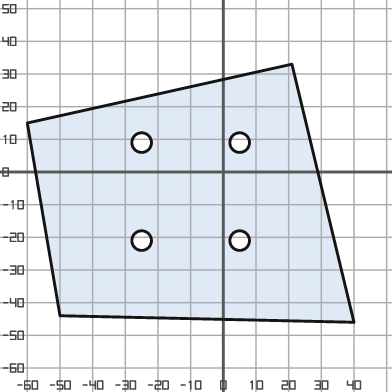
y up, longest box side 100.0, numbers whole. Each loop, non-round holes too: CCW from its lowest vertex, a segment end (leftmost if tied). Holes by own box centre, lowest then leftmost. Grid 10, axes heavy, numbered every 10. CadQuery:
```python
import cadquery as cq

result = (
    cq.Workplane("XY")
    .moveTo(40.0, -46.0)
    .lineTo(21.0, 33.0)
    .lineTo(-60.0, 15.0)
    .lineTo(-50.0, -44.0)
    .close()
    .moveTo(-25.0, -21.0)
    .circle(3.0)
    .moveTo(5.0, -21.0)
    .circle(3.0)
    .moveTo(-25.0, 9.0)
    .circle(3.0)
    .moveTo(5.0, 9.0)
    .circle(3.0)
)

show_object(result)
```